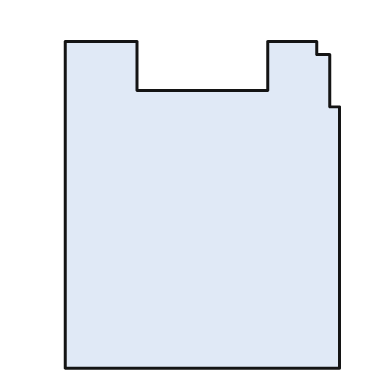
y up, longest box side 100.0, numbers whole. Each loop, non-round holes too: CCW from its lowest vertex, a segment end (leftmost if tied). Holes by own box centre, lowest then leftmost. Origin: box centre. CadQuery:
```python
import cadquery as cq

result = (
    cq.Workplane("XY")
    .moveTo(-42.0, -50.0)
    .lineTo(42.0, -50.0)
    .lineTo(42.0, 30.0)
    .lineTo(39.0, 30.0)
    .lineTo(39.0, 46.0)
    .lineTo(35.0, 46.0)
    .lineTo(35.0, 50.0)
    .lineTo(20.0, 50.0)
    .lineTo(20.0, 35.0)
    .lineTo(-20.0, 35.0)
    .lineTo(-20.0, 50.0)
    .lineTo(-42.0, 50.0)
    .close()
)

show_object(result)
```